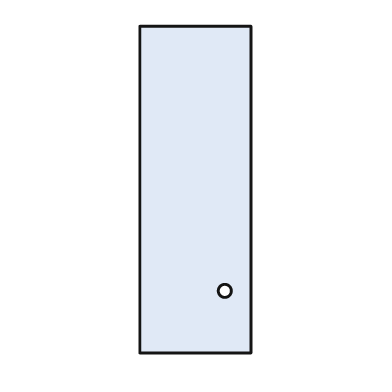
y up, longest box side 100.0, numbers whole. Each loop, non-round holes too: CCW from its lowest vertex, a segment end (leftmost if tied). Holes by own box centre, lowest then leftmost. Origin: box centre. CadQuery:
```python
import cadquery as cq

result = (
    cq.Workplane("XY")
    .moveTo(-17.0, -50.0)
    .lineTo(17.0, -50.0)
    .lineTo(17.0, 50.0)
    .lineTo(-17.0, 50.0)
    .close()
    .moveTo(9.0, -31.0)
    .circle(2.0)
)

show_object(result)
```